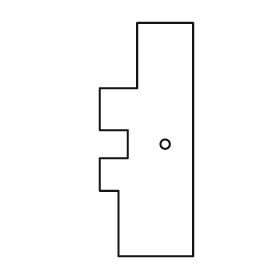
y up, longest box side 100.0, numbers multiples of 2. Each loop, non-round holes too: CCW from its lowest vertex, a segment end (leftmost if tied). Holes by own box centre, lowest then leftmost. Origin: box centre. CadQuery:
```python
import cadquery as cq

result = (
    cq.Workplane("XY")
    .moveTo(-12.0, -50.0)
    .lineTo(20.0, -50.0)
    .lineTo(20.0, 50.0)
    .lineTo(-4.0, 50.0)
    .lineTo(-4.0, 22.0)
    .lineTo(-20.0, 22.0)
    .lineTo(-20.0, 4.0)
    .lineTo(-8.0, 4.0)
    .lineTo(-8.0, -8.0)
    .lineTo(-20.0, -8.0)
    .lineTo(-20.0, -22.0)
    .lineTo(-12.0, -22.0)
    .close()
    .moveTo(8.0, -2.0)
    .circle(2.0)
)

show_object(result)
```